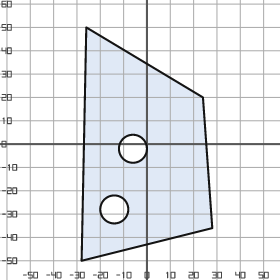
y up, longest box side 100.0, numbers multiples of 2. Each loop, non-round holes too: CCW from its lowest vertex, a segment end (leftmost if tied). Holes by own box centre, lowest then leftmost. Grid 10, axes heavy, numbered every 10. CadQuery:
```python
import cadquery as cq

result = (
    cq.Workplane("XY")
    .moveTo(-28.0, -50.0)
    .lineTo(28.0, -36.0)
    .lineTo(24.0, 20.0)
    .lineTo(-26.0, 50.0)
    .close()
    .moveTo(-14.0, -28.0)
    .circle(6.0)
    .moveTo(-6.0, -2.0)
    .circle(6.0)
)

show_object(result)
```